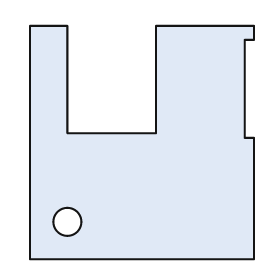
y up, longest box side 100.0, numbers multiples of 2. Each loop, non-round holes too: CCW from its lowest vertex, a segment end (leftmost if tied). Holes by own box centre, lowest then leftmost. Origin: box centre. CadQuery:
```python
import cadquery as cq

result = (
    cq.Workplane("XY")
    .moveTo(-48.0, -50.0)
    .lineTo(48.0, -50.0)
    .lineTo(48.0, 2.0)
    .lineTo(44.0, 2.0)
    .lineTo(44.0, 44.0)
    .lineTo(48.0, 44.0)
    .lineTo(48.0, 50.0)
    .lineTo(6.0, 50.0)
    .lineTo(6.0, 4.0)
    .lineTo(-32.0, 4.0)
    .lineTo(-32.0, 50.0)
    .lineTo(-48.0, 50.0)
    .close()
    .moveTo(-32.0, -34.0)
    .circle(6.0)
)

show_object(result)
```